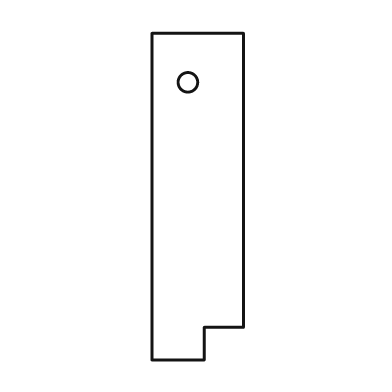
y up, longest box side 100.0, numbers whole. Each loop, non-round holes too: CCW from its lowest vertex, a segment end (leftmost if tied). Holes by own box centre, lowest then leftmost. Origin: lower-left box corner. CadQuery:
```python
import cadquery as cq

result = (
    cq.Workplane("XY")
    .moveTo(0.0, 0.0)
    .lineTo(16.0, 0.0)
    .lineTo(16.0, 10.0)
    .lineTo(28.0, 10.0)
    .lineTo(28.0, 100.0)
    .lineTo(0.0, 100.0)
    .close()
    .moveTo(11.0, 85.0)
    .circle(3.0)
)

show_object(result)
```